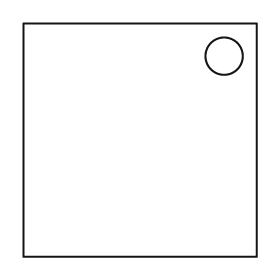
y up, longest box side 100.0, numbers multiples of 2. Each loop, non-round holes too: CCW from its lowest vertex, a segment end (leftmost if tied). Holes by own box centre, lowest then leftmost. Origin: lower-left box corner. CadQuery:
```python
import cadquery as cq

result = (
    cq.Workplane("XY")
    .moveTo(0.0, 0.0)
    .lineTo(100.0, 0.0)
    .lineTo(100.0, 100.0)
    .lineTo(0.0, 100.0)
    .close()
    .moveTo(86.0, 86.0)
    .circle(8.0)
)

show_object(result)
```